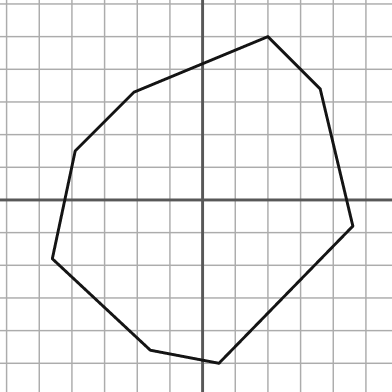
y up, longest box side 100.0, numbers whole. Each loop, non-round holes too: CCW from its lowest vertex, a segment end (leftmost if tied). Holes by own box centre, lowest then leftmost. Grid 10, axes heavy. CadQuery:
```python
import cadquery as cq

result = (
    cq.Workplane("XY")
    .moveTo(5.0, -50.0)
    .lineTo(46.0, -8.0)
    .lineTo(36.0, 34.0)
    .lineTo(20.0, 50.0)
    .lineTo(-21.0, 33.0)
    .lineTo(-39.0, 15.0)
    .lineTo(-46.0, -18.0)
    .lineTo(-16.0, -46.0)
    .close()
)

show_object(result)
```